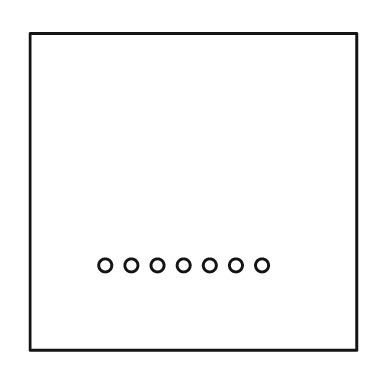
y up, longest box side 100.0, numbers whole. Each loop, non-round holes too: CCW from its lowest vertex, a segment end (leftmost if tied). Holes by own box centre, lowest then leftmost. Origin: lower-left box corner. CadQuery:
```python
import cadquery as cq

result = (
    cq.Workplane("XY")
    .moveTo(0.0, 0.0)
    .lineTo(100.0, 0.0)
    .lineTo(100.0, 97.0)
    .lineTo(0.0, 97.0)
    .close()
    .moveTo(23.0, 26.0)
    .circle(2.0)
    .moveTo(31.0, 26.0)
    .circle(2.0)
    .moveTo(39.0, 26.0)
    .circle(2.0)
    .moveTo(47.0, 26.0)
    .circle(2.0)
    .moveTo(55.0, 26.0)
    .circle(2.0)
    .moveTo(63.0, 26.0)
    .circle(2.0)
    .moveTo(71.0, 26.0)
    .circle(2.0)
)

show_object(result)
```